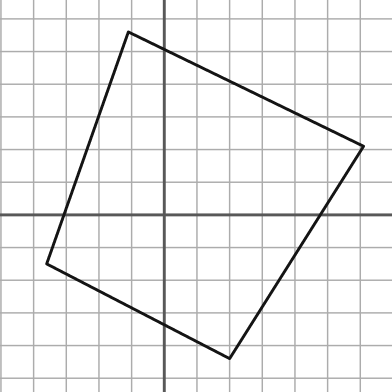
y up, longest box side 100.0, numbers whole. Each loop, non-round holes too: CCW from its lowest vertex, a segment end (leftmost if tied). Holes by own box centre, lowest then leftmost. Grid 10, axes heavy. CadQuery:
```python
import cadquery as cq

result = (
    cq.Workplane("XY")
    .moveTo(20.0, -44.0)
    .lineTo(61.0, 21.0)
    .lineTo(-11.0, 56.0)
    .lineTo(-36.0, -15.0)
    .close()
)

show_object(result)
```